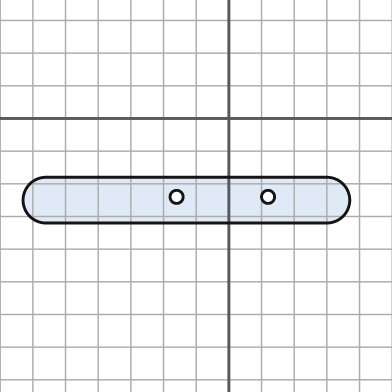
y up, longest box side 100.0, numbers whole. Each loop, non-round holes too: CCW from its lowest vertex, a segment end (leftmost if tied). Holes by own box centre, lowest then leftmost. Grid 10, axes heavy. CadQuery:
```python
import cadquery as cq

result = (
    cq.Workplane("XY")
    .moveTo(-56.0, -32.0)
    .lineTo(30.0, -32.0)
    .threePointArc((37.0, -25.0), (30.0, -18.0))
    .lineTo(-56.0, -18.0)
    .threePointArc((-63.0, -25.0), (-56.0, -32.0))
    .close()
    .moveTo(-16.0, -24.0)
    .circle(2.0)
    .moveTo(12.0, -24.0)
    .circle(2.0)
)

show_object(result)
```